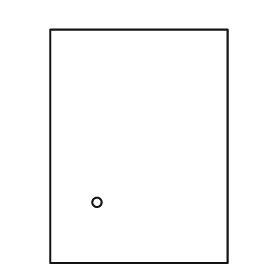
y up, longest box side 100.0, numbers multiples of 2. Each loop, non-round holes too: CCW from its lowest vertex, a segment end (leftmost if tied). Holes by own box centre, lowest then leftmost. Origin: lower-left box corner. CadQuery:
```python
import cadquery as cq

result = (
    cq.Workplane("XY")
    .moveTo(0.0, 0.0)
    .lineTo(76.0, 0.0)
    .lineTo(76.0, 100.0)
    .lineTo(0.0, 100.0)
    .close()
    .moveTo(20.0, 26.0)
    .circle(2.0)
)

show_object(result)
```